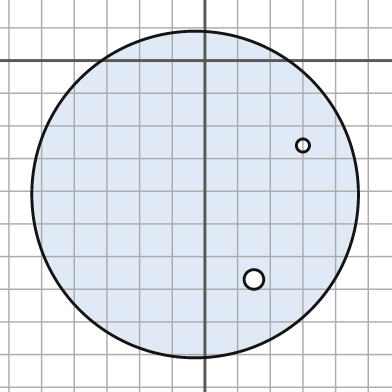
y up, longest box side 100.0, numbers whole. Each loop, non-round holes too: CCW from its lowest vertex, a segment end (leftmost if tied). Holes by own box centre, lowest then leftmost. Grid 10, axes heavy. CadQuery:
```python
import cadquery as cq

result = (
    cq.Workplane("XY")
    .moveTo(-3.0, -41.0)
    .circle(50.0)
    .moveTo(15.0, -67.0)
    .circle(3.0)
    .moveTo(30.0, -26.0)
    .circle(2.0)
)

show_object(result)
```